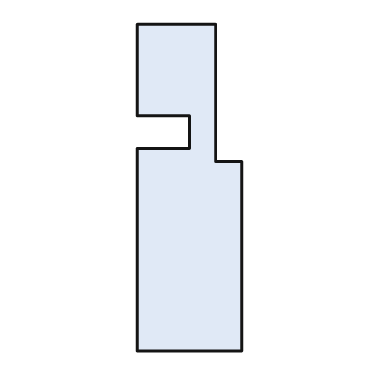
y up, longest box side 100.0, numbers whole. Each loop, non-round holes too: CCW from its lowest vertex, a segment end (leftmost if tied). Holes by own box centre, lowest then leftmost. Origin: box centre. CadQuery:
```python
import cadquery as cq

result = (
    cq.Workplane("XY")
    .moveTo(-16.0, -50.0)
    .lineTo(16.0, -50.0)
    .lineTo(16.0, 8.0)
    .lineTo(8.0, 8.0)
    .lineTo(8.0, 50.0)
    .lineTo(-16.0, 50.0)
    .lineTo(-16.0, 22.0)
    .lineTo(0.0, 22.0)
    .lineTo(0.0, 12.0)
    .lineTo(-16.0, 12.0)
    .close()
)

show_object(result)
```